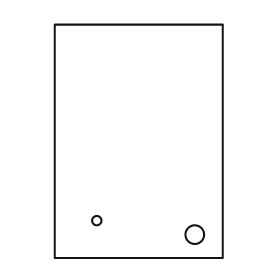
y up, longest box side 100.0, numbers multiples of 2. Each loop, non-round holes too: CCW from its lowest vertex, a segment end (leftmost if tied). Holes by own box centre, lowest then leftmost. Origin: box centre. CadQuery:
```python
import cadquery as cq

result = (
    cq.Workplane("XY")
    .moveTo(-36.0, -50.0)
    .lineTo(36.0, -50.0)
    .lineTo(36.0, 50.0)
    .lineTo(-36.0, 50.0)
    .close()
    .moveTo(24.0, -40.0)
    .circle(4.0)
    .moveTo(-18.0, -34.0)
    .circle(2.0)
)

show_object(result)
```